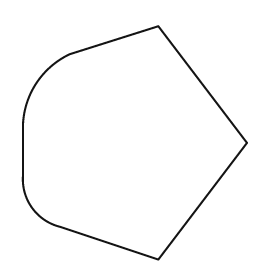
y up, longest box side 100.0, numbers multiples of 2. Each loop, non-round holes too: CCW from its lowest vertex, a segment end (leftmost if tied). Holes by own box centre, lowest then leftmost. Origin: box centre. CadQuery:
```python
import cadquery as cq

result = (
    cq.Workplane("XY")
    .moveTo(10.0, -50.0)
    .lineTo(48.0, 0.0)
    .lineTo(10.0, 50.0)
    .lineTo(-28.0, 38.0)
    .threePointArc((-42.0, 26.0), (-48.0, 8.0))
    .lineTo(-48.0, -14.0)
    .threePointArc((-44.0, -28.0), (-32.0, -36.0))
    .close()
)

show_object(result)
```